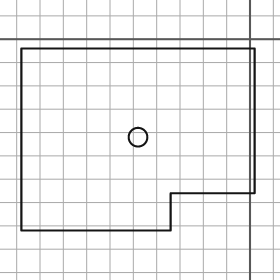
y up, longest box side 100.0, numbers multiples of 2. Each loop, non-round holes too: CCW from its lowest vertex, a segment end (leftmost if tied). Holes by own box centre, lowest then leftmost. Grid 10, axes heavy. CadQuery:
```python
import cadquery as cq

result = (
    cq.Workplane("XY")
    .moveTo(-98.0, -82.0)
    .lineTo(-34.0, -82.0)
    .lineTo(-34.0, -66.0)
    .lineTo(2.0, -66.0)
    .lineTo(2.0, -4.0)
    .lineTo(-98.0, -4.0)
    .close()
    .moveTo(-48.0, -42.0)
    .circle(4.0)
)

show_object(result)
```